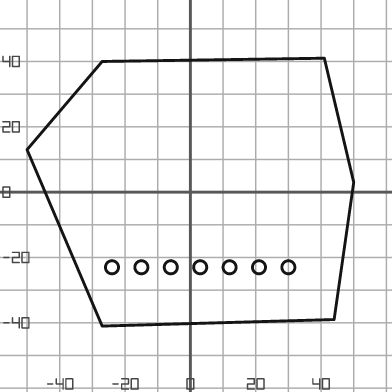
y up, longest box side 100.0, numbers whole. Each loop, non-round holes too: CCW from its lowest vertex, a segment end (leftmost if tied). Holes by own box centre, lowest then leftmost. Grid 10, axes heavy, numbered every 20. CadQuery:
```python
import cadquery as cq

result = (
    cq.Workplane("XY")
    .moveTo(-27.0, -41.0)
    .lineTo(44.0, -39.0)
    .lineTo(50.0, 3.0)
    .lineTo(41.0, 41.0)
    .lineTo(-27.0, 40.0)
    .lineTo(-50.0, 13.0)
    .close()
    .moveTo(-24.0, -23.0)
    .circle(2.0)
    .moveTo(-15.0, -23.0)
    .circle(2.0)
    .moveTo(-6.0, -23.0)
    .circle(2.0)
    .moveTo(3.0, -23.0)
    .circle(2.0)
    .moveTo(12.0, -23.0)
    .circle(2.0)
    .moveTo(21.0, -23.0)
    .circle(2.0)
    .moveTo(30.0, -23.0)
    .circle(2.0)
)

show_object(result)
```